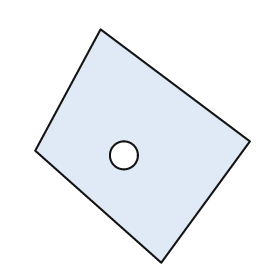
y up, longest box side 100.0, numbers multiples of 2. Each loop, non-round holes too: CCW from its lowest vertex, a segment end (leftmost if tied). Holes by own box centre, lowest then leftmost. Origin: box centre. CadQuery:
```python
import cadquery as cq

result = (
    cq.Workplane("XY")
    .moveTo(8.0, -50.0)
    .lineTo(46.0, 2.0)
    .lineTo(-18.0, 50.0)
    .lineTo(-46.0, -2.0)
    .close()
    .moveTo(-8.0, -4.0)
    .circle(6.0)
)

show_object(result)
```